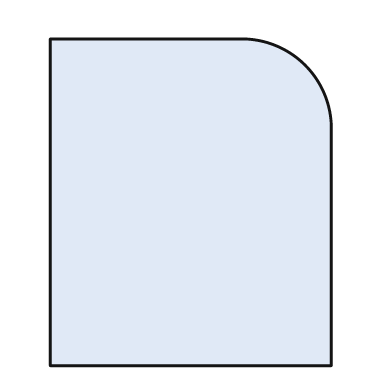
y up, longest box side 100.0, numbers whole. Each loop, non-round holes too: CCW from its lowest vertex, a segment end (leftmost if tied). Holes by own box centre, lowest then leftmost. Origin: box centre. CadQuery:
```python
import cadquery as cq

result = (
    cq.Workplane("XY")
    .moveTo(-43.0, -50.0)
    .lineTo(43.0, -50.0)
    .lineTo(43.0, 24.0)
    .threePointArc((35.0, 42.0), (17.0, 50.0))
    .lineTo(-43.0, 50.0)
    .close()
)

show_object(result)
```